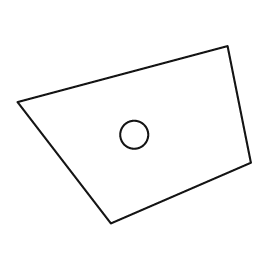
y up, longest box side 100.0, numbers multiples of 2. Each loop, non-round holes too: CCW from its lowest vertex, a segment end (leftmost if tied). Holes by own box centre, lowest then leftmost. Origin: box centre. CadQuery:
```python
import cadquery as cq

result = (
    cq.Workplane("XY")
    .moveTo(-10.0, -38.0)
    .lineTo(50.0, -12.0)
    .lineTo(40.0, 38.0)
    .lineTo(-50.0, 14.0)
    .close()
    .moveTo(0.0, 0.0)
    .circle(6.0)
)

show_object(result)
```